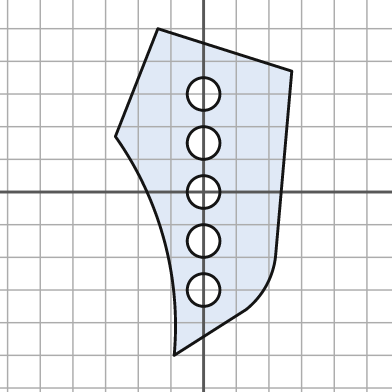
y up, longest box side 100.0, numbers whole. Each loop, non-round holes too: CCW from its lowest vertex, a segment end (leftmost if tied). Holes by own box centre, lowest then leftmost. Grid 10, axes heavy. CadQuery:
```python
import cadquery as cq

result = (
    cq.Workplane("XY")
    .moveTo(-9.0, -50.0)
    .lineTo(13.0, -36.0)
    .threePointArc((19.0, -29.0), (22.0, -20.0))
    .lineTo(27.0, 37.0)
    .lineTo(-14.0, 50.0)
    .lineTo(-27.0, 17.0)
    .threePointArc((-12.0, -15.0), (-9.0, -50.0))
    .close()
    .moveTo(0.0, -30.0)
    .circle(5.0)
    .moveTo(0.0, -15.0)
    .circle(5.0)
    .moveTo(0.0, 0.0)
    .circle(5.0)
    .moveTo(0.0, 15.0)
    .circle(5.0)
    .moveTo(0.0, 30.0)
    .circle(5.0)
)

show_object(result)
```